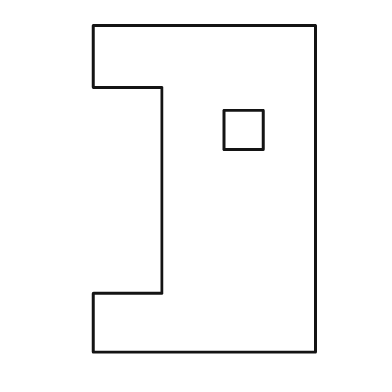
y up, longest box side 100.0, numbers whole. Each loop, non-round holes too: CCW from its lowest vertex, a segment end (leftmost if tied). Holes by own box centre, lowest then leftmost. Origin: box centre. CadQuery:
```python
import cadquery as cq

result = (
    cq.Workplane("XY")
    .moveTo(-34.0, -50.0)
    .lineTo(34.0, -50.0)
    .lineTo(34.0, 50.0)
    .lineTo(-34.0, 50.0)
    .lineTo(-34.0, 31.0)
    .lineTo(-13.0, 31.0)
    .lineTo(-13.0, -32.0)
    .lineTo(-34.0, -32.0)
    .close()
    .moveTo(6.0, 12.0)
    .lineTo(18.0, 12.0)
    .lineTo(18.0, 24.0)
    .lineTo(6.0, 24.0)
    .close()
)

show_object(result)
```